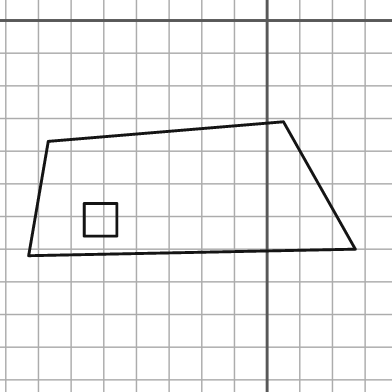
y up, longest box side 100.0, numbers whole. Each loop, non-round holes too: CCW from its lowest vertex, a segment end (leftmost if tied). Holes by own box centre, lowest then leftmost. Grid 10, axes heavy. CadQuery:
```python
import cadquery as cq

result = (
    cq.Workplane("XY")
    .moveTo(-73.0, -72.0)
    .lineTo(27.0, -70.0)
    .lineTo(5.0, -31.0)
    .lineTo(-67.0, -37.0)
    .close()
    .moveTo(-56.0, -66.0)
    .lineTo(-46.0, -66.0)
    .lineTo(-46.0, -56.0)
    .lineTo(-56.0, -56.0)
    .close()
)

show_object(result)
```